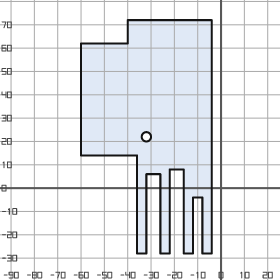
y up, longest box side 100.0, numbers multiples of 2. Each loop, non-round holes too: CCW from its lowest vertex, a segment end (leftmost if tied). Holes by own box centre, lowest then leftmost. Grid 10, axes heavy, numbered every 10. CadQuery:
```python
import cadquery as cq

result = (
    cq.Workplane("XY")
    .moveTo(-36.0, -28.0)
    .lineTo(-32.0, -28.0)
    .lineTo(-32.0, 6.0)
    .lineTo(-26.0, 6.0)
    .lineTo(-26.0, -28.0)
    .lineTo(-22.0, -28.0)
    .lineTo(-22.0, 8.0)
    .lineTo(-16.0, 8.0)
    .lineTo(-16.0, -28.0)
    .lineTo(-12.0, -28.0)
    .lineTo(-12.0, -4.0)
    .lineTo(-8.0, -4.0)
    .lineTo(-8.0, -28.0)
    .lineTo(-4.0, -28.0)
    .lineTo(-4.0, 72.0)
    .lineTo(-40.0, 72.0)
    .lineTo(-40.0, 62.0)
    .lineTo(-60.0, 62.0)
    .lineTo(-60.0, 14.0)
    .lineTo(-36.0, 14.0)
    .close()
    .moveTo(-32.0, 22.0)
    .circle(2.0)
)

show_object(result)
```